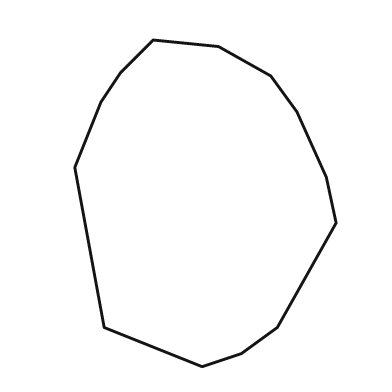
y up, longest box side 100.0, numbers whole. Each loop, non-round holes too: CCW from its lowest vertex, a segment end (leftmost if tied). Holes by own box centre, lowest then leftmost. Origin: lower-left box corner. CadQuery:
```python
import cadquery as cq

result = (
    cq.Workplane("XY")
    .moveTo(39.0, 0.0)
    .lineTo(51.0, 4.0)
    .lineTo(62.0, 12.0)
    .lineTo(80.0, 44.0)
    .lineTo(77.0, 58.0)
    .lineTo(68.0, 78.0)
    .lineTo(60.0, 89.0)
    .lineTo(44.0, 98.0)
    .lineTo(24.0, 100.0)
    .lineTo(14.0, 90.0)
    .lineTo(8.0, 81.0)
    .lineTo(0.0, 61.0)
    .lineTo(9.0, 12.0)
    .close()
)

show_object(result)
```